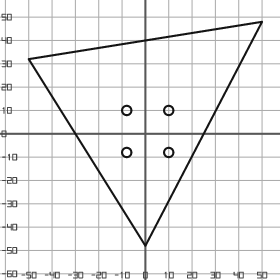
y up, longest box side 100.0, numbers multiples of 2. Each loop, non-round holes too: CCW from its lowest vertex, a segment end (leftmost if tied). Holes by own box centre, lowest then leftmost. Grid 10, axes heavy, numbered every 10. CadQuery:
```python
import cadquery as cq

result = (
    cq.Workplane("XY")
    .moveTo(0.0, -48.0)
    .lineTo(50.0, 48.0)
    .lineTo(-50.0, 32.0)
    .close()
    .moveTo(-8.0, -8.0)
    .circle(2.0)
    .moveTo(10.0, -8.0)
    .circle(2.0)
    .moveTo(-8.0, 10.0)
    .circle(2.0)
    .moveTo(10.0, 10.0)
    .circle(2.0)
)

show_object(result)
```